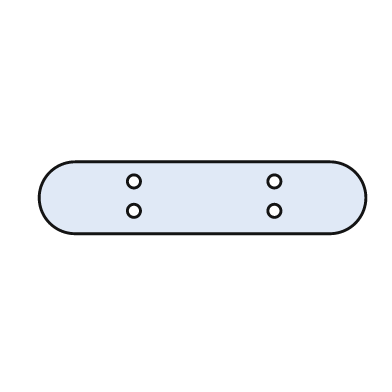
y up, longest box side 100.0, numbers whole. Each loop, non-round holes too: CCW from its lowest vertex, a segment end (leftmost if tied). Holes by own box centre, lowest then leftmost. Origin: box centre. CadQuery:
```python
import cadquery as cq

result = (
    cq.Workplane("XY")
    .moveTo(-39.0, -11.0)
    .lineTo(39.0, -11.0)
    .threePointArc((50.0, 0.0), (39.0, 11.0))
    .lineTo(-39.0, 11.0)
    .threePointArc((-50.0, 0.0), (-39.0, -11.0))
    .close()
    .moveTo(-21.0, -4.0)
    .circle(2.0)
    .moveTo(22.0, -4.0)
    .circle(2.0)
    .moveTo(-21.0, 5.0)
    .circle(2.0)
    .moveTo(22.0, 5.0)
    .circle(2.0)
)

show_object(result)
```